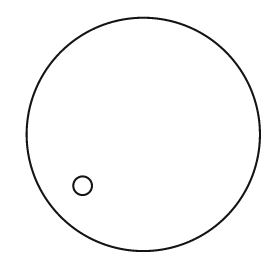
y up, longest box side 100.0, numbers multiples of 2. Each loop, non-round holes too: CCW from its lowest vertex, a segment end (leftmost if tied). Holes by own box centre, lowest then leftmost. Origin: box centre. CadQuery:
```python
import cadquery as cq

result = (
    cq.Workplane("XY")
    .moveTo(0.0, 0.0)
    .circle(50.0)
    .moveTo(-26.0, -22.0)
    .circle(4.0)
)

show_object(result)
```